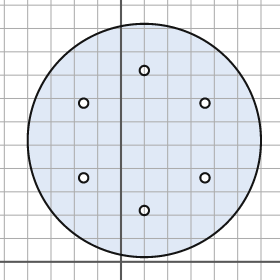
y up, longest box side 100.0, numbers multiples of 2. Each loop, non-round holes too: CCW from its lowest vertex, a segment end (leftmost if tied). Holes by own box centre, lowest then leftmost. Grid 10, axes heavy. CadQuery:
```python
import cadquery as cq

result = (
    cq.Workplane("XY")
    .moveTo(10.0, 52.0)
    .circle(50.0)
    .moveTo(10.0, 22.0)
    .circle(2.0)
    .moveTo(-16.0, 36.0)
    .circle(2.0)
    .moveTo(36.0, 36.0)
    .circle(2.0)
    .moveTo(-16.0, 68.0)
    .circle(2.0)
    .moveTo(36.0, 68.0)
    .circle(2.0)
    .moveTo(10.0, 82.0)
    .circle(2.0)
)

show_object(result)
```